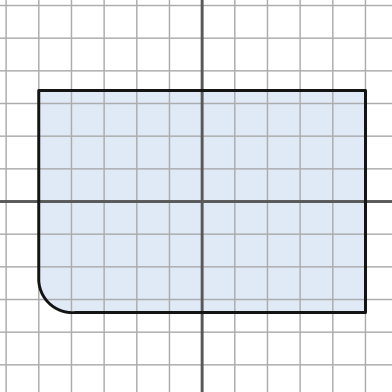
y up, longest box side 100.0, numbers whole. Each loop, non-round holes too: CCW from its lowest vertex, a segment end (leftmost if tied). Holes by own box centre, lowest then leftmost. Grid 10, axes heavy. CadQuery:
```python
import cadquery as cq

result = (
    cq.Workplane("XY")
    .moveTo(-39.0, -34.0)
    .lineTo(50.0, -34.0)
    .lineTo(50.0, 34.0)
    .lineTo(-50.0, 34.0)
    .lineTo(-50.0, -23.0)
    .threePointArc((-47.0, -31.0), (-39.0, -34.0))
    .close()
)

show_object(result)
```